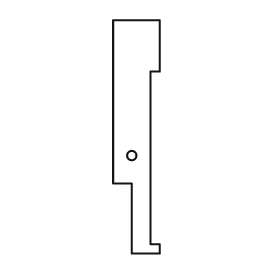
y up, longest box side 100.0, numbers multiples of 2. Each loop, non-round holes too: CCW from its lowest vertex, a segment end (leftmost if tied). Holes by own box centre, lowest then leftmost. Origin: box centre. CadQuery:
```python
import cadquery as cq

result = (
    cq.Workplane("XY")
    .moveTo(-2.0, -50.0)
    .lineTo(10.0, -50.0)
    .lineTo(10.0, -46.0)
    .lineTo(6.0, -46.0)
    .lineTo(6.0, 28.0)
    .lineTo(10.0, 28.0)
    .lineTo(10.0, 50.0)
    .lineTo(-10.0, 50.0)
    .lineTo(-10.0, -20.0)
    .lineTo(-2.0, -20.0)
    .close()
    .moveTo(-2.0, -8.0)
    .circle(2.0)
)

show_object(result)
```